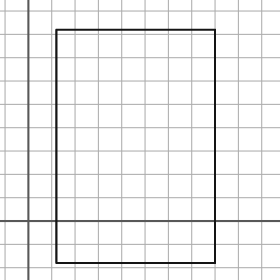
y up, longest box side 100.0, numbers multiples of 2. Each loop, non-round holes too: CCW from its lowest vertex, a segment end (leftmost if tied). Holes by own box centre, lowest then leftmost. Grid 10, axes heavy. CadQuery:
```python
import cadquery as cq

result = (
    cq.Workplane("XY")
    .moveTo(12.0, -18.0)
    .lineTo(80.0, -18.0)
    .lineTo(80.0, 82.0)
    .lineTo(12.0, 82.0)
    .close()
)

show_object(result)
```